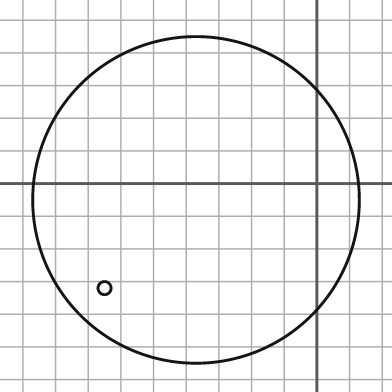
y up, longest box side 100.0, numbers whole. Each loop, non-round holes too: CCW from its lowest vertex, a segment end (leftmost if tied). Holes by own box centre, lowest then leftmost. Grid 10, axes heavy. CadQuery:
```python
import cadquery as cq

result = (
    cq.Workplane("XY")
    .moveTo(-37.0, -5.0)
    .circle(50.0)
    .moveTo(-65.0, -32.0)
    .circle(2.0)
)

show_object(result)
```